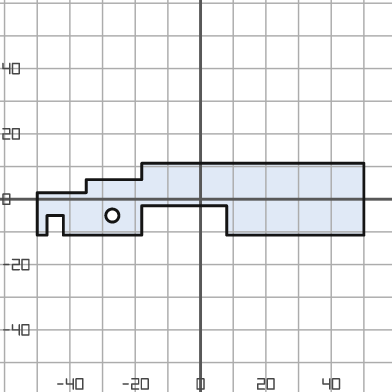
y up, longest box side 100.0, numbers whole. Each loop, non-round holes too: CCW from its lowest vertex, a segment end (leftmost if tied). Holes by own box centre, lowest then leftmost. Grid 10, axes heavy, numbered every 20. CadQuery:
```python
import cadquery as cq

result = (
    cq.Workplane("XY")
    .moveTo(-50.0, -11.0)
    .lineTo(-47.0, -11.0)
    .lineTo(-47.0, -5.0)
    .lineTo(-42.0, -5.0)
    .lineTo(-42.0, -11.0)
    .lineTo(-18.0, -11.0)
    .lineTo(-18.0, -2.0)
    .lineTo(8.0, -2.0)
    .lineTo(8.0, -11.0)
    .lineTo(50.0, -11.0)
    .lineTo(50.0, 11.0)
    .lineTo(-18.0, 11.0)
    .lineTo(-18.0, 6.0)
    .lineTo(-35.0, 6.0)
    .lineTo(-35.0, 2.0)
    .lineTo(-50.0, 2.0)
    .close()
    .moveTo(-27.0, -5.0)
    .circle(2.0)
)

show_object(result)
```